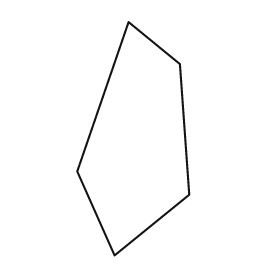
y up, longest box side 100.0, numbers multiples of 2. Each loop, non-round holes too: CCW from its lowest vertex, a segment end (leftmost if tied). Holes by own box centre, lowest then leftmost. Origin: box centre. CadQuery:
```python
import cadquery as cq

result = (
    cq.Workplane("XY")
    .moveTo(-8.0, -50.0)
    .lineTo(24.0, -24.0)
    .lineTo(20.0, 32.0)
    .lineTo(-2.0, 50.0)
    .lineTo(-24.0, -14.0)
    .close()
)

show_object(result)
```